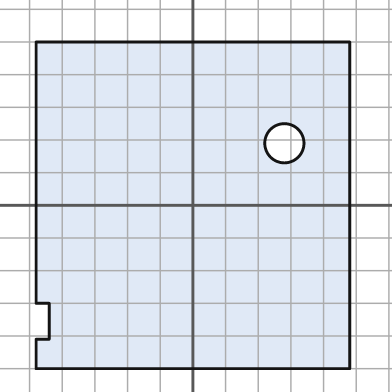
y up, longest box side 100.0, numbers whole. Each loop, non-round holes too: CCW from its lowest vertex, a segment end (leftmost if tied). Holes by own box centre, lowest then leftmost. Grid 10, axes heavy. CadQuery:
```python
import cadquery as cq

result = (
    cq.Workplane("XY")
    .moveTo(-48.0, -50.0)
    .lineTo(48.0, -50.0)
    .lineTo(48.0, 50.0)
    .lineTo(-48.0, 50.0)
    .lineTo(-48.0, -30.0)
    .lineTo(-44.0, -30.0)
    .lineTo(-44.0, -41.0)
    .lineTo(-48.0, -41.0)
    .close()
    .moveTo(28.0, 19.0)
    .circle(6.0)
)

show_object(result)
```